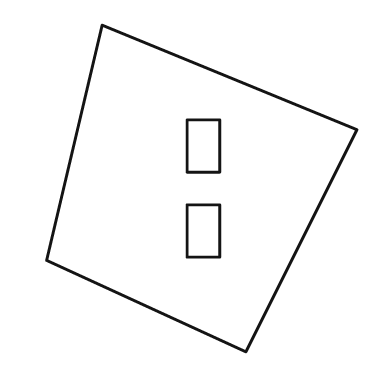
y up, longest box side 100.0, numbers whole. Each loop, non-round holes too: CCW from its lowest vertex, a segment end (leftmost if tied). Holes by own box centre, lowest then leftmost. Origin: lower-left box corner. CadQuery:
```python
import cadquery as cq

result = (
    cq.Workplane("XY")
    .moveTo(61.0, 0.0)
    .lineTo(95.0, 68.0)
    .lineTo(17.0, 100.0)
    .lineTo(0.0, 28.0)
    .close()
    .moveTo(43.0, 29.0)
    .lineTo(53.0, 29.0)
    .lineTo(53.0, 45.0)
    .lineTo(43.0, 45.0)
    .close()
    .moveTo(43.0, 55.0)
    .lineTo(53.0, 55.0)
    .lineTo(53.0, 71.0)
    .lineTo(43.0, 71.0)
    .close()
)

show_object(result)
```